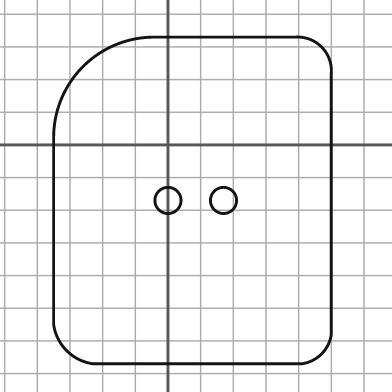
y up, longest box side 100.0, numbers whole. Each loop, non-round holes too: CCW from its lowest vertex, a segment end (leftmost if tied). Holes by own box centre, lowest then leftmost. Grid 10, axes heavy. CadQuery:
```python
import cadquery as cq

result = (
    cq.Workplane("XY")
    .moveTo(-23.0, -67.0)
    .lineTo(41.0, -67.0)
    .threePointArc((47.0, -64.0), (50.0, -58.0))
    .lineTo(50.0, 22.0)
    .threePointArc((47.0, 30.0), (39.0, 33.0))
    .lineTo(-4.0, 33.0)
    .threePointArc((-26.0, 24.0), (-35.0, 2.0))
    .lineTo(-35.0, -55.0)
    .threePointArc((-31.0, -63.0), (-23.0, -67.0))
    .close()
    .moveTo(0.0, -17.0)
    .circle(4.0)
    .moveTo(17.0, -17.0)
    .circle(4.0)
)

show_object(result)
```